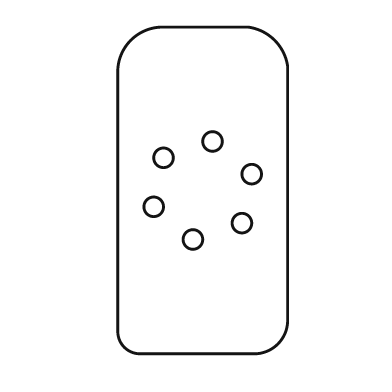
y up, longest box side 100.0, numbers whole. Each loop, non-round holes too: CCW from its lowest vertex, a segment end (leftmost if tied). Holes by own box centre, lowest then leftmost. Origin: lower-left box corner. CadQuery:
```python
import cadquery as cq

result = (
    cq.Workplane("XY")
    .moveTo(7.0, 0.0)
    .lineTo(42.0, 0.0)
    .threePointArc((49.0, 3.0), (52.0, 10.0))
    .lineTo(52.0, 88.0)
    .threePointArc((48.0, 96.0), (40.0, 100.0))
    .lineTo(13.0, 100.0)
    .threePointArc((4.0, 96.0), (0.0, 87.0))
    .lineTo(0.0, 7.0)
    .threePointArc((2.0, 2.0), (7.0, 0.0))
    .close()
    .moveTo(23.0, 35.0)
    .circle(3.0)
    .moveTo(38.0, 40.0)
    .circle(3.0)
    .moveTo(11.0, 45.0)
    .circle(3.0)
    .moveTo(41.0, 55.0)
    .circle(3.0)
    .moveTo(14.0, 60.0)
    .circle(3.0)
    .moveTo(29.0, 65.0)
    .circle(3.0)
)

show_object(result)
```